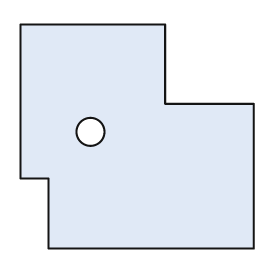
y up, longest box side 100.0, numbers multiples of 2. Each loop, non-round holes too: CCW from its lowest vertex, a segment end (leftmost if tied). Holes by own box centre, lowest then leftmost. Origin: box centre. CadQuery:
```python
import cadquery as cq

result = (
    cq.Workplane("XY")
    .moveTo(-38.0, -48.0)
    .lineTo(50.0, -48.0)
    .lineTo(50.0, 14.0)
    .lineTo(12.0, 14.0)
    .lineTo(12.0, 48.0)
    .lineTo(-50.0, 48.0)
    .lineTo(-50.0, -18.0)
    .lineTo(-38.0, -18.0)
    .close()
    .moveTo(-20.0, 2.0)
    .circle(6.0)
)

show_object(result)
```